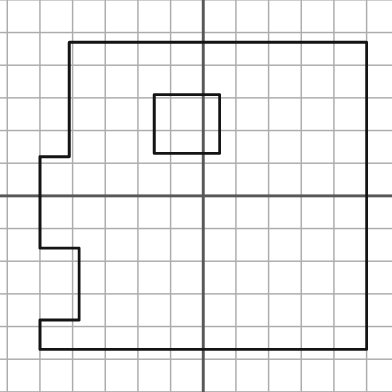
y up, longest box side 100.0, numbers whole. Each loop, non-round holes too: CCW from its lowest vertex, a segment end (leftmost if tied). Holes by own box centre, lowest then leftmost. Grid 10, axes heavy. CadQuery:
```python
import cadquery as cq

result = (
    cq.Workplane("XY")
    .moveTo(-50.0, -47.0)
    .lineTo(50.0, -47.0)
    .lineTo(50.0, 47.0)
    .lineTo(-41.0, 47.0)
    .lineTo(-41.0, 12.0)
    .lineTo(-50.0, 12.0)
    .lineTo(-50.0, -16.0)
    .lineTo(-38.0, -16.0)
    .lineTo(-38.0, -38.0)
    .lineTo(-50.0, -38.0)
    .close()
    .moveTo(-15.0, 13.0)
    .lineTo(5.0, 13.0)
    .lineTo(5.0, 31.0)
    .lineTo(-15.0, 31.0)
    .close()
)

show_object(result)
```